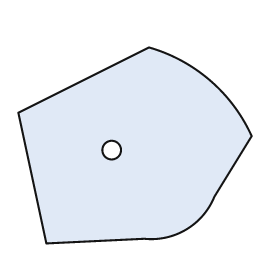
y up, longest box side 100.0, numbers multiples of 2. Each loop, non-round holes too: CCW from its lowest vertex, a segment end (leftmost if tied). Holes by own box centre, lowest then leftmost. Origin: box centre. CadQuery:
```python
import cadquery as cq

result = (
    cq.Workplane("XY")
    .moveTo(-38.0, -42.0)
    .lineTo(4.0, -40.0)
    .threePointArc((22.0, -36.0), (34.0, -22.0))
    .lineTo(50.0, 4.0)
    .threePointArc((32.0, 28.0), (6.0, 42.0))
    .lineTo(-50.0, 14.0)
    .close()
    .moveTo(-10.0, -2.0)
    .circle(4.0)
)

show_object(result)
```